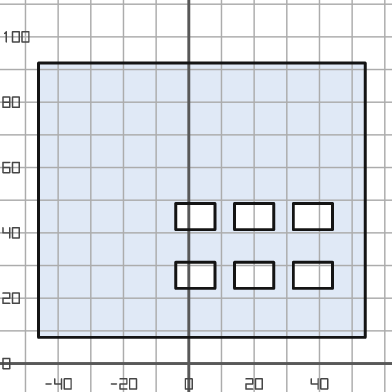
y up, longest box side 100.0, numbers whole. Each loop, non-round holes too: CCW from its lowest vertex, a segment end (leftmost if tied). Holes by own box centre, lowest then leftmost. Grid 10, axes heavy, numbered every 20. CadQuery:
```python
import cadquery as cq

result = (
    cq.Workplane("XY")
    .moveTo(-46.0, 8.0)
    .lineTo(54.0, 8.0)
    .lineTo(54.0, 92.0)
    .lineTo(-46.0, 92.0)
    .close()
    .moveTo(-4.0, 23.0)
    .lineTo(8.0, 23.0)
    .lineTo(8.0, 31.0)
    .lineTo(-4.0, 31.0)
    .close()
    .moveTo(14.0, 23.0)
    .lineTo(26.0, 23.0)
    .lineTo(26.0, 31.0)
    .lineTo(14.0, 31.0)
    .close()
    .moveTo(32.0, 23.0)
    .lineTo(44.0, 23.0)
    .lineTo(44.0, 31.0)
    .lineTo(32.0, 31.0)
    .close()
    .moveTo(-4.0, 41.0)
    .lineTo(8.0, 41.0)
    .lineTo(8.0, 49.0)
    .lineTo(-4.0, 49.0)
    .close()
    .moveTo(14.0, 41.0)
    .lineTo(26.0, 41.0)
    .lineTo(26.0, 49.0)
    .lineTo(14.0, 49.0)
    .close()
    .moveTo(32.0, 41.0)
    .lineTo(44.0, 41.0)
    .lineTo(44.0, 49.0)
    .lineTo(32.0, 49.0)
    .close()
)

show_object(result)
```